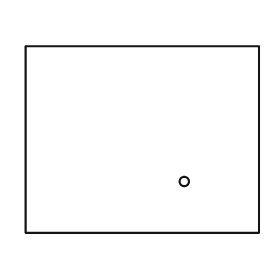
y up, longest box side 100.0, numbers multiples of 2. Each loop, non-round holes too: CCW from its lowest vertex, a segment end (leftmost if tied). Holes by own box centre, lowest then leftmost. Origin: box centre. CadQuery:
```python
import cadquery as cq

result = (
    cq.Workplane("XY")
    .moveTo(-50.0, -40.0)
    .lineTo(50.0, -40.0)
    .lineTo(50.0, 40.0)
    .lineTo(-50.0, 40.0)
    .close()
    .moveTo(18.0, -18.0)
    .circle(2.0)
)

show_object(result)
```